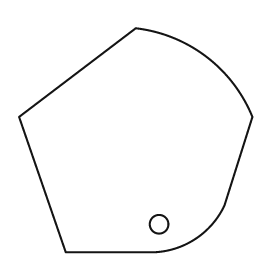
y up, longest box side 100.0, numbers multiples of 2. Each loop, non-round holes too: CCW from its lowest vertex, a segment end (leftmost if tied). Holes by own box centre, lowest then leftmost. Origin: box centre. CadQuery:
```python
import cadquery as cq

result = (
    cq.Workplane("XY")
    .moveTo(-30.0, -48.0)
    .lineTo(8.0, -48.0)
    .threePointArc((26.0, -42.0), (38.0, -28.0))
    .lineTo(50.0, 10.0)
    .threePointArc((30.0, 36.0), (0.0, 48.0))
    .lineTo(-50.0, 10.0)
    .close()
    .moveTo(10.0, -36.0)
    .circle(4.0)
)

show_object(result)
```